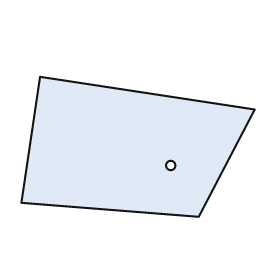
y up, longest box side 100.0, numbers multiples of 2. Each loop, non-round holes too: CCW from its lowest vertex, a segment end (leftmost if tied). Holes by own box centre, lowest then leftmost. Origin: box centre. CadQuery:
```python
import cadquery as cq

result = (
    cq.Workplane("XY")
    .moveTo(26.0, -30.0)
    .lineTo(50.0, 16.0)
    .lineTo(-42.0, 30.0)
    .lineTo(-50.0, -24.0)
    .close()
    .moveTo(14.0, -8.0)
    .circle(2.0)
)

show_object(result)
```